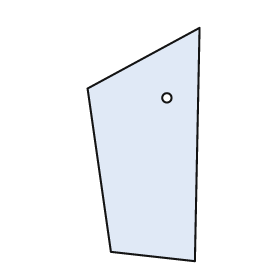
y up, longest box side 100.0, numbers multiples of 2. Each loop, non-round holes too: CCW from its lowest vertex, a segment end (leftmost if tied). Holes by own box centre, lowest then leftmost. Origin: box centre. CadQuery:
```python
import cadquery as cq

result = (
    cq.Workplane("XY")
    .moveTo(22.0, -50.0)
    .lineTo(24.0, 50.0)
    .lineTo(-24.0, 24.0)
    .lineTo(-14.0, -46.0)
    .close()
    .moveTo(10.0, 20.0)
    .circle(2.0)
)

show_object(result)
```